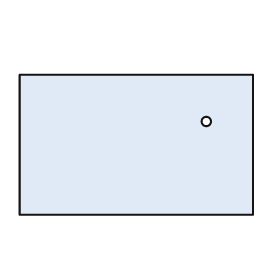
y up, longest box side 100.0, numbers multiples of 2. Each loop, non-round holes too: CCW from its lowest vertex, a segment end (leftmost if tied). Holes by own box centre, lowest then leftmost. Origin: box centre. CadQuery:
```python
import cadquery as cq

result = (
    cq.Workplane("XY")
    .moveTo(-50.0, -30.0)
    .lineTo(50.0, -30.0)
    .lineTo(50.0, 30.0)
    .lineTo(-50.0, 30.0)
    .close()
    .moveTo(30.0, 10.0)
    .circle(2.0)
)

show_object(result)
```